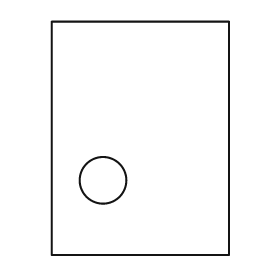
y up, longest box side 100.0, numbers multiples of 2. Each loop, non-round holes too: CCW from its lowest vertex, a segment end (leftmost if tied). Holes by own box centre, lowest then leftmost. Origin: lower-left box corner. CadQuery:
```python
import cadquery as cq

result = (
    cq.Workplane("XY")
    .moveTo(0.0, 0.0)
    .lineTo(76.0, 0.0)
    .lineTo(76.0, 100.0)
    .lineTo(0.0, 100.0)
    .close()
    .moveTo(22.0, 32.0)
    .circle(10.0)
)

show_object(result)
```